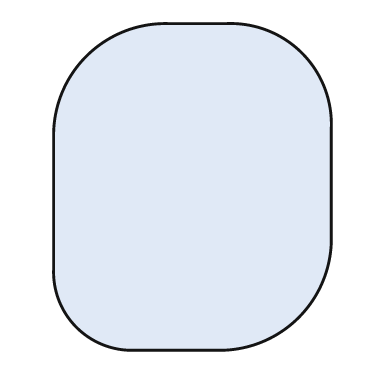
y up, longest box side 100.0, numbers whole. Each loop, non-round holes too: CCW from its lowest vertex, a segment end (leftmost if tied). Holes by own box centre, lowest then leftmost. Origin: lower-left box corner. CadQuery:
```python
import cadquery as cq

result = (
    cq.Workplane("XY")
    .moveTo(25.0, 0.0)
    .lineTo(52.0, 0.0)
    .threePointArc((75.0, 10.0), (85.0, 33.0))
    .lineTo(85.0, 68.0)
    .threePointArc((76.0, 91.0), (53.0, 100.0))
    .lineTo(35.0, 100.0)
    .threePointArc((10.0, 90.0), (0.0, 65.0))
    .lineTo(0.0, 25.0)
    .threePointArc((7.0, 7.0), (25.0, 0.0))
    .close()
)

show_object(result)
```